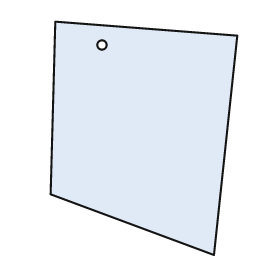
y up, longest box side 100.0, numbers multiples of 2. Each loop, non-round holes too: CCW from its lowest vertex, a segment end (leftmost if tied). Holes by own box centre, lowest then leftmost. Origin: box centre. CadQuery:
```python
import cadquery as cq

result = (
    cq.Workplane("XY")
    .moveTo(30.0, -50.0)
    .lineTo(40.0, 44.0)
    .lineTo(-38.0, 50.0)
    .lineTo(-40.0, -24.0)
    .close()
    .moveTo(-18.0, 40.0)
    .circle(2.0)
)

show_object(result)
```